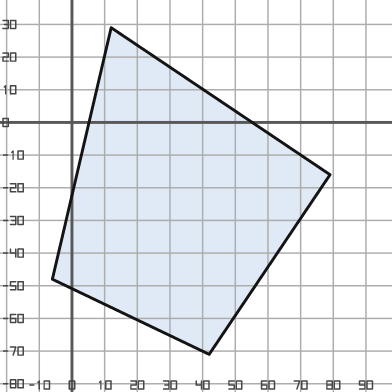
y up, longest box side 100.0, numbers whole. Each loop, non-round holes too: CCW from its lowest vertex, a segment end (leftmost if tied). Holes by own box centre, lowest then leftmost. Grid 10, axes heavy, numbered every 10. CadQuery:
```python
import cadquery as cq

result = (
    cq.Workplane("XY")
    .moveTo(42.0, -71.0)
    .lineTo(79.0, -16.0)
    .lineTo(12.0, 29.0)
    .lineTo(-6.0, -48.0)
    .close()
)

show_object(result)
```